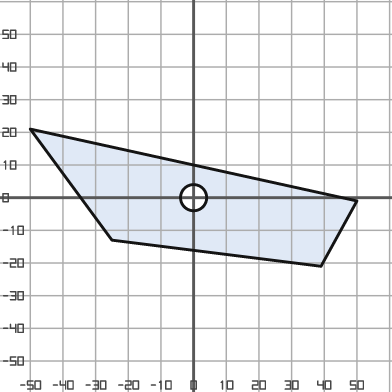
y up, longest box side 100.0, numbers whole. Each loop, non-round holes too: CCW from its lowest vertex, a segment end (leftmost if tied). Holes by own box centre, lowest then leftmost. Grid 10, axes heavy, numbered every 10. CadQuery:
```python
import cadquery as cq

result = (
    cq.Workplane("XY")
    .moveTo(39.0, -21.0)
    .lineTo(50.0, -1.0)
    .lineTo(-50.0, 21.0)
    .lineTo(-25.0, -13.0)
    .close()
    .moveTo(0.0, 0.0)
    .circle(4.0)
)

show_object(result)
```